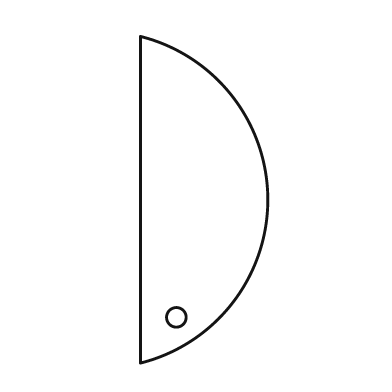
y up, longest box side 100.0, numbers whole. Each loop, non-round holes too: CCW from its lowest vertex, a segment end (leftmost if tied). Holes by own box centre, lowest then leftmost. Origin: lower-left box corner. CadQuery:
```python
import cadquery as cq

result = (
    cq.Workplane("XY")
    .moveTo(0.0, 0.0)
    .threePointArc((39.0, 50.0), (0.0, 100.0))
    .close()
    .moveTo(11.0, 14.0)
    .circle(3.0)
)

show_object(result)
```